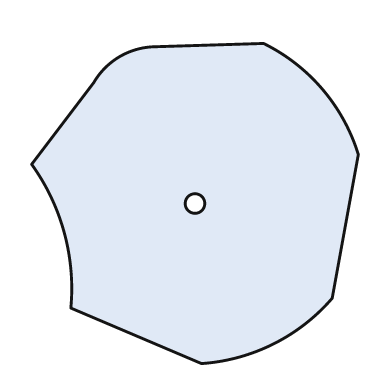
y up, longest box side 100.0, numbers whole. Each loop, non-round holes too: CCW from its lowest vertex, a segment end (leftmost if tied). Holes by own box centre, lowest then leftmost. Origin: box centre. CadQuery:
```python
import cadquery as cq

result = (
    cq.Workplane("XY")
    .moveTo(2.0, -49.0)
    .threePointArc((24.0, -43.0), (42.0, -29.0))
    .lineTo(50.0, 15.0)
    .threePointArc((39.0, 35.0), (21.0, 49.0))
    .lineTo(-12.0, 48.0)
    .threePointArc((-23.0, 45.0), (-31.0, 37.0))
    .lineTo(-50.0, 12.0)
    .threePointArc((-40.0, -9.0), (-38.0, -32.0))
    .close()
    .moveTo(0.0, 0.0)
    .circle(3.0)
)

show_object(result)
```